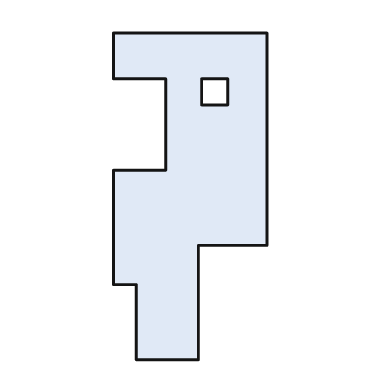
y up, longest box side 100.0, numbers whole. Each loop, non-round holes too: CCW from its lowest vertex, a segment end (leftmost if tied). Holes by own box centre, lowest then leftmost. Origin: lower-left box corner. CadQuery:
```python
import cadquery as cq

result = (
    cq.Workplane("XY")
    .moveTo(7.0, 0.0)
    .lineTo(26.0, 0.0)
    .lineTo(26.0, 35.0)
    .lineTo(47.0, 35.0)
    .lineTo(47.0, 100.0)
    .lineTo(0.0, 100.0)
    .lineTo(0.0, 86.0)
    .lineTo(16.0, 86.0)
    .lineTo(16.0, 58.0)
    .lineTo(0.0, 58.0)
    .lineTo(0.0, 23.0)
    .lineTo(7.0, 23.0)
    .close()
    .moveTo(27.0, 78.0)
    .lineTo(35.0, 78.0)
    .lineTo(35.0, 86.0)
    .lineTo(27.0, 86.0)
    .close()
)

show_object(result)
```